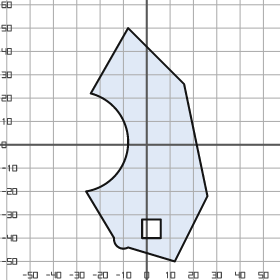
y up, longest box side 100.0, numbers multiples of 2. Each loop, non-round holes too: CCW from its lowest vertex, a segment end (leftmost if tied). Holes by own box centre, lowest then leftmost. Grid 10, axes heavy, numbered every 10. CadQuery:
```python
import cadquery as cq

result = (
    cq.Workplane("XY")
    .moveTo(12.0, -50.0)
    .lineTo(26.0, -22.0)
    .lineTo(16.0, 26.0)
    .lineTo(-8.0, 50.0)
    .lineTo(-24.0, 22.0)
    .threePointArc((-8.0, 0.0), (-26.0, -20.0))
    .lineTo(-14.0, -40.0)
    .threePointArc((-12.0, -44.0), (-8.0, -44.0))
    .close()
    .moveTo(-2.0, -40.0)
    .lineTo(6.0, -40.0)
    .lineTo(6.0, -32.0)
    .lineTo(-2.0, -32.0)
    .close()
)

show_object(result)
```